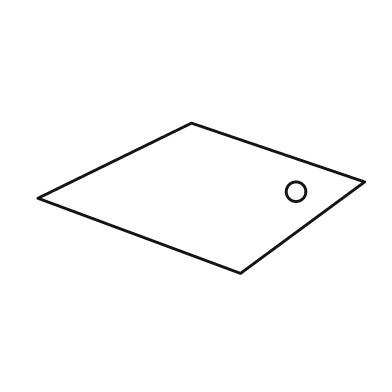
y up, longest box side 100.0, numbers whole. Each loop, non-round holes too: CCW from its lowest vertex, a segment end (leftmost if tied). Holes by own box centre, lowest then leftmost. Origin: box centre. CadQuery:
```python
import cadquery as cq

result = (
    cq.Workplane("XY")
    .moveTo(12.0, -23.0)
    .lineTo(50.0, 5.0)
    .lineTo(-3.0, 23.0)
    .lineTo(-50.0, 0.0)
    .close()
    .moveTo(29.0, 2.0)
    .circle(3.0)
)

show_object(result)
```